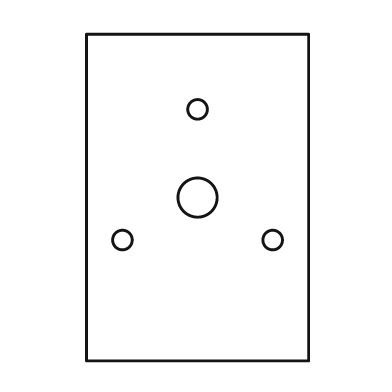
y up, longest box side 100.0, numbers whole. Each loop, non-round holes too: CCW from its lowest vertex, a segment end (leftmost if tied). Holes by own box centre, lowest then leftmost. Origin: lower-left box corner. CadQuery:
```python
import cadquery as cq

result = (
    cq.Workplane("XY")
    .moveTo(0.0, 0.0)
    .lineTo(68.0, 0.0)
    .lineTo(68.0, 100.0)
    .lineTo(0.0, 100.0)
    .close()
    .moveTo(11.0, 37.0)
    .circle(3.0)
    .moveTo(57.0, 37.0)
    .circle(3.0)
    .moveTo(34.0, 50.0)
    .circle(6.0)
    .moveTo(34.0, 77.0)
    .circle(3.0)
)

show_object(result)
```